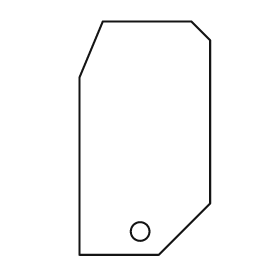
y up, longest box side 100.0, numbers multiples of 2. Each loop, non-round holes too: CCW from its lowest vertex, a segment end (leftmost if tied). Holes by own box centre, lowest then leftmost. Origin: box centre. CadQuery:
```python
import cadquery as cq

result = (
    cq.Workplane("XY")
    .moveTo(-28.0, -50.0)
    .lineTo(6.0, -50.0)
    .lineTo(28.0, -28.0)
    .lineTo(28.0, 42.0)
    .lineTo(20.0, 50.0)
    .lineTo(-18.0, 50.0)
    .lineTo(-28.0, 26.0)
    .close()
    .moveTo(-2.0, -40.0)
    .circle(4.0)
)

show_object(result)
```